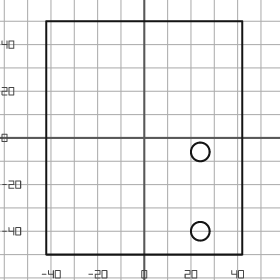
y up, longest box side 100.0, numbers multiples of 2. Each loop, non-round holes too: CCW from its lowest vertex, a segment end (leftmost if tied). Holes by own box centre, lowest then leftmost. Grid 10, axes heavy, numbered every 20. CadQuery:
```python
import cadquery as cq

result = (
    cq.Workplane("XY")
    .moveTo(-42.0, -50.0)
    .lineTo(42.0, -50.0)
    .lineTo(42.0, 50.0)
    .lineTo(-42.0, 50.0)
    .close()
    .moveTo(24.0, -40.0)
    .circle(4.0)
    .moveTo(24.0, -6.0)
    .circle(4.0)
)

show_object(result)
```